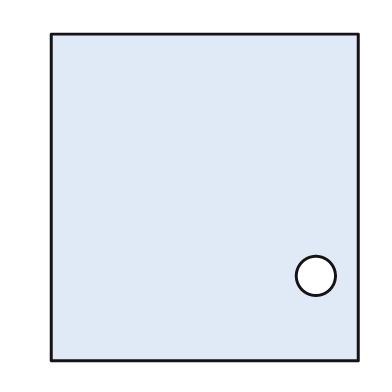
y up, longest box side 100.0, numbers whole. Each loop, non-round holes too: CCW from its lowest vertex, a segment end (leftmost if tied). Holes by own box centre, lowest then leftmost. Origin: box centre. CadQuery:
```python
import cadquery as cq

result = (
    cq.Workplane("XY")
    .moveTo(-47.0, -50.0)
    .lineTo(47.0, -50.0)
    .lineTo(47.0, 50.0)
    .lineTo(-47.0, 50.0)
    .close()
    .moveTo(34.0, -24.0)
    .circle(6.0)
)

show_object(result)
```